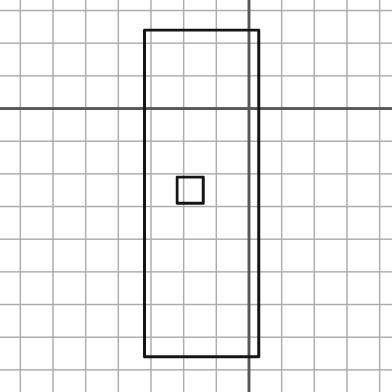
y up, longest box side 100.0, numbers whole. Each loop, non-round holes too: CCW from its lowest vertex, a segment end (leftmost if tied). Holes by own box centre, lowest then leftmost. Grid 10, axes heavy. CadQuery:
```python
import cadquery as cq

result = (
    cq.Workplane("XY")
    .moveTo(-32.0, -76.0)
    .lineTo(3.0, -76.0)
    .lineTo(3.0, 24.0)
    .lineTo(-32.0, 24.0)
    .close()
    .moveTo(-22.0, -29.0)
    .lineTo(-14.0, -29.0)
    .lineTo(-14.0, -21.0)
    .lineTo(-22.0, -21.0)
    .close()
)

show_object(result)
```